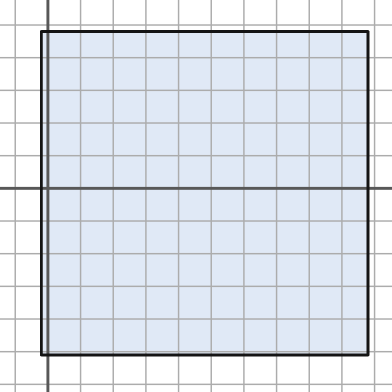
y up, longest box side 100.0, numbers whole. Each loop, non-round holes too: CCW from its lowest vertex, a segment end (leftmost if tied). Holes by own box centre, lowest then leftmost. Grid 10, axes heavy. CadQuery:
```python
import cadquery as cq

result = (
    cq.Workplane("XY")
    .moveTo(-2.0, -51.0)
    .lineTo(98.0, -51.0)
    .lineTo(98.0, 48.0)
    .lineTo(-2.0, 48.0)
    .close()
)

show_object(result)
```